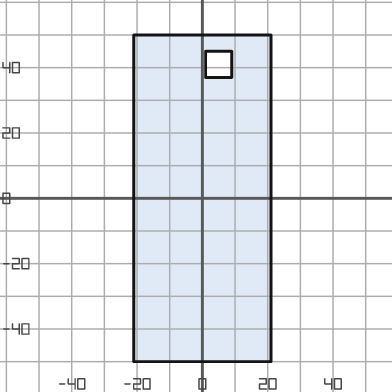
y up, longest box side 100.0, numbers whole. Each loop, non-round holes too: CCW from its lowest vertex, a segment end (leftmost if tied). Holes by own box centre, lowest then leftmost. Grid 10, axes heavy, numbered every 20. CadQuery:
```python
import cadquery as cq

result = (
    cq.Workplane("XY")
    .moveTo(-21.0, -50.0)
    .lineTo(21.0, -50.0)
    .lineTo(21.0, 50.0)
    .lineTo(-21.0, 50.0)
    .close()
    .moveTo(1.0, 37.0)
    .lineTo(9.0, 37.0)
    .lineTo(9.0, 45.0)
    .lineTo(1.0, 45.0)
    .close()
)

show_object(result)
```